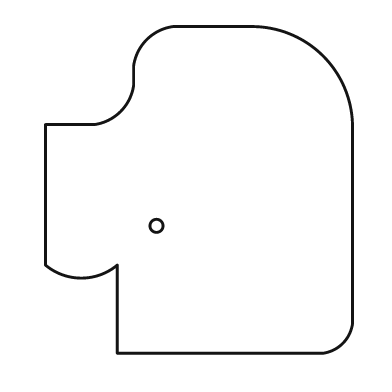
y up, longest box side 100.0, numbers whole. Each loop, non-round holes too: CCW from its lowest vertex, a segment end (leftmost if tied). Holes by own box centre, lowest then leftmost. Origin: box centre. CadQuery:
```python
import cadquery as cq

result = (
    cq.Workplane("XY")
    .moveTo(-25.0, -50.0)
    .lineTo(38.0, -50.0)
    .threePointArc((44.0, -47.0), (47.0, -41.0))
    .lineTo(47.0, 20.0)
    .threePointArc((38.0, 41.0), (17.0, 50.0))
    .lineTo(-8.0, 50.0)
    .threePointArc((-16.0, 46.0), (-20.0, 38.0))
    .lineTo(-20.0, 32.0)
    .threePointArc((-24.0, 24.0), (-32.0, 20.0))
    .lineTo(-47.0, 20.0)
    .lineTo(-47.0, -23.0)
    .threePointArc((-36.0, -27.0), (-25.0, -23.0))
    .close()
    .moveTo(-13.0, -11.0)
    .circle(2.0)
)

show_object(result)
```